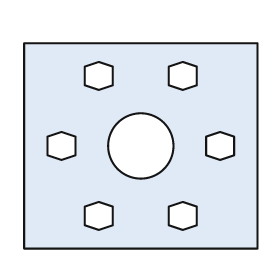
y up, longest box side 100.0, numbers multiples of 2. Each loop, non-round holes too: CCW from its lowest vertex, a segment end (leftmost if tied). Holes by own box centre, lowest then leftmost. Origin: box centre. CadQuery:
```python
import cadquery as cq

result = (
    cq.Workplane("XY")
    .moveTo(-50.0, -44.0)
    .lineTo(50.0, -44.0)
    .lineTo(50.0, 44.0)
    .lineTo(-50.0, 44.0)
    .close()
    .moveTo(-18.0, -36.0)
    .lineTo(-12.0, -34.0)
    .lineTo(-12.0, -26.0)
    .lineTo(-18.0, -24.0)
    .lineTo(-24.0, -26.0)
    .lineTo(-24.0, -34.0)
    .close()
    .moveTo(18.0, -36.0)
    .lineTo(24.0, -34.0)
    .lineTo(24.0, -26.0)
    .lineTo(18.0, -24.0)
    .lineTo(12.0, -26.0)
    .lineTo(12.0, -34.0)
    .close()
    .moveTo(-34.0, -6.0)
    .lineTo(-28.0, -4.0)
    .lineTo(-28.0, 4.0)
    .lineTo(-34.0, 6.0)
    .lineTo(-40.0, 4.0)
    .lineTo(-40.0, -4.0)
    .close()
    .moveTo(0.0, 0.0)
    .circle(14.0)
    .moveTo(34.0, -6.0)
    .lineTo(40.0, -4.0)
    .lineTo(40.0, 4.0)
    .lineTo(34.0, 6.0)
    .lineTo(28.0, 4.0)
    .lineTo(28.0, -4.0)
    .close()
    .moveTo(-18.0, 24.0)
    .lineTo(-12.0, 26.0)
    .lineTo(-12.0, 34.0)
    .lineTo(-18.0, 36.0)
    .lineTo(-24.0, 34.0)
    .lineTo(-24.0, 26.0)
    .close()
    .moveTo(18.0, 24.0)
    .lineTo(24.0, 26.0)
    .lineTo(24.0, 34.0)
    .lineTo(18.0, 36.0)
    .lineTo(12.0, 34.0)
    .lineTo(12.0, 26.0)
    .close()
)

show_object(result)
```